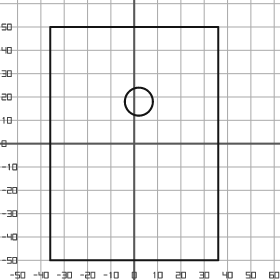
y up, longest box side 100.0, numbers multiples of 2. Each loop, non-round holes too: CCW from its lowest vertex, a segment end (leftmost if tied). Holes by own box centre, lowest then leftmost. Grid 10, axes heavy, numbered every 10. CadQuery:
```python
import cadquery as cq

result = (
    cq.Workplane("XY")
    .moveTo(-36.0, -50.0)
    .lineTo(36.0, -50.0)
    .lineTo(36.0, 50.0)
    .lineTo(-36.0, 50.0)
    .close()
    .moveTo(2.0, 18.0)
    .circle(6.0)
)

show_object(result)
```